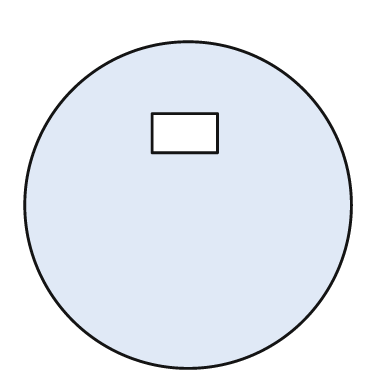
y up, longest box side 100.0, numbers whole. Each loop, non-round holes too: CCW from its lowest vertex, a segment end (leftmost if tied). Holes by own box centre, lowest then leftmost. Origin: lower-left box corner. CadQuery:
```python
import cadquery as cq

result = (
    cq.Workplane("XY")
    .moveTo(50.0, 50.0)
    .circle(50.0)
    .moveTo(39.0, 66.0)
    .lineTo(59.0, 66.0)
    .lineTo(59.0, 78.0)
    .lineTo(39.0, 78.0)
    .close()
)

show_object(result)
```